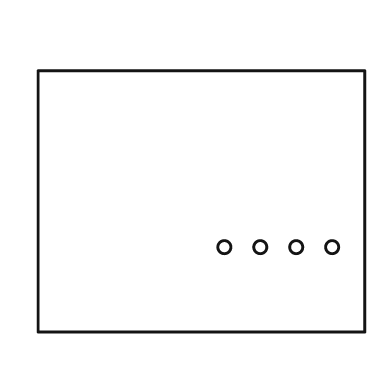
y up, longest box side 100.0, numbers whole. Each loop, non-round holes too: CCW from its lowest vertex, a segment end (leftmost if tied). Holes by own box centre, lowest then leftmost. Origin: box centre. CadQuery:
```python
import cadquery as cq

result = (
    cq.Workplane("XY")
    .moveTo(-50.0, -40.0)
    .lineTo(50.0, -40.0)
    .lineTo(50.0, 40.0)
    .lineTo(-50.0, 40.0)
    .close()
    .moveTo(7.0, -14.0)
    .circle(2.0)
    .moveTo(18.0, -14.0)
    .circle(2.0)
    .moveTo(29.0, -14.0)
    .circle(2.0)
    .moveTo(40.0, -14.0)
    .circle(2.0)
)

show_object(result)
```